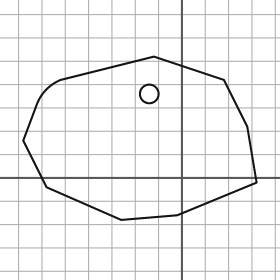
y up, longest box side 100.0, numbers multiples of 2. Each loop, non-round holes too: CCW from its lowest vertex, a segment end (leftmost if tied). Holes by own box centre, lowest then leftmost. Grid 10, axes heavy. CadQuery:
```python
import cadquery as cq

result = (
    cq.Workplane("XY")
    .moveTo(-26.0, -18.0)
    .lineTo(-2.0, -16.0)
    .lineTo(32.0, -2.0)
    .lineTo(28.0, 22.0)
    .lineTo(18.0, 42.0)
    .lineTo(-12.0, 52.0)
    .lineTo(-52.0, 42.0)
    .threePointArc((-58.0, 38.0), (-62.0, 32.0))
    .lineTo(-68.0, 16.0)
    .lineTo(-58.0, -4.0)
    .close()
    .moveTo(-14.0, 36.0)
    .circle(4.0)
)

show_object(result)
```